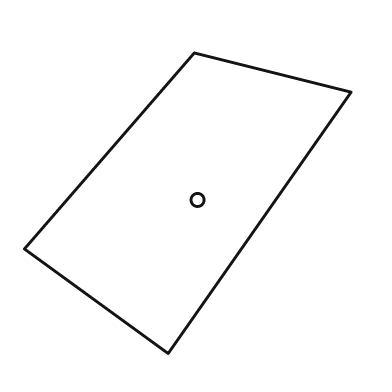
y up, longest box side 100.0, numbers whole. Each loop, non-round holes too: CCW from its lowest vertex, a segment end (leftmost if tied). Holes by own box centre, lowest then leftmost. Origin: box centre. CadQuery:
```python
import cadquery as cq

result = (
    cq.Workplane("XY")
    .moveTo(-6.0, -46.0)
    .lineTo(50.0, 34.0)
    .lineTo(2.0, 46.0)
    .lineTo(-50.0, -14.0)
    .close()
    .moveTo(3.0, 1.0)
    .circle(2.0)
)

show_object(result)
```